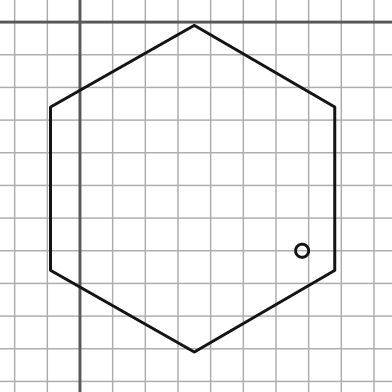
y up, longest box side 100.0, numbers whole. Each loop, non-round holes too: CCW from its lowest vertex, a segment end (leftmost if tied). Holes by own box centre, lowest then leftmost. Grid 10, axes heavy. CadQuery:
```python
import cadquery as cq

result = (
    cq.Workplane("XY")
    .moveTo(35.0, -101.0)
    .lineTo(78.0, -76.0)
    .lineTo(78.0, -26.0)
    .lineTo(35.0, -1.0)
    .lineTo(-9.0, -26.0)
    .lineTo(-9.0, -76.0)
    .close()
    .moveTo(68.0, -70.0)
    .circle(2.0)
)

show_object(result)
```